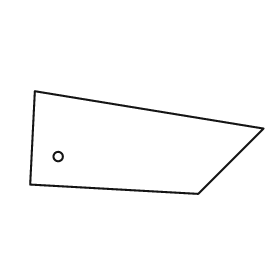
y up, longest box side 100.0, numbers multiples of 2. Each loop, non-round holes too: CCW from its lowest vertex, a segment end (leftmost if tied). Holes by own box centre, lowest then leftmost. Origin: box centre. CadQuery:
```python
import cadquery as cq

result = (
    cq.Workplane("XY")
    .moveTo(22.0, -22.0)
    .lineTo(50.0, 6.0)
    .lineTo(-48.0, 22.0)
    .lineTo(-50.0, -18.0)
    .close()
    .moveTo(-38.0, -6.0)
    .circle(2.0)
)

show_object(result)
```